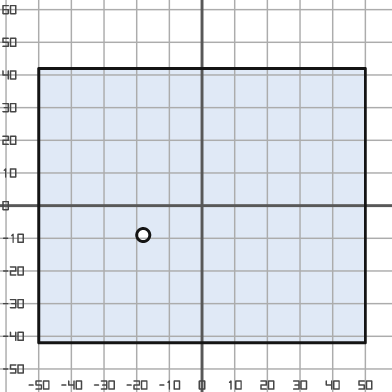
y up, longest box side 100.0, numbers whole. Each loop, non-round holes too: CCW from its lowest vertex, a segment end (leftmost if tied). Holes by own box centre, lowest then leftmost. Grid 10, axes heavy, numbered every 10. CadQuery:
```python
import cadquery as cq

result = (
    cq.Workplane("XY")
    .moveTo(-50.0, -42.0)
    .lineTo(50.0, -42.0)
    .lineTo(50.0, 42.0)
    .lineTo(-50.0, 42.0)
    .close()
    .moveTo(-18.0, -9.0)
    .circle(2.0)
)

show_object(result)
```